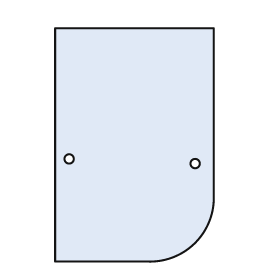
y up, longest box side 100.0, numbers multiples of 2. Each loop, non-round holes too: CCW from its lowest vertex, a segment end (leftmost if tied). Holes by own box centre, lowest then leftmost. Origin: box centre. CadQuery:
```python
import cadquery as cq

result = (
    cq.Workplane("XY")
    .moveTo(-34.0, -50.0)
    .lineTo(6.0, -50.0)
    .threePointArc((26.0, -42.0), (34.0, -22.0))
    .lineTo(34.0, 50.0)
    .lineTo(-34.0, 50.0)
    .close()
    .moveTo(26.0, -8.0)
    .circle(2.0)
    .moveTo(-28.0, -6.0)
    .circle(2.0)
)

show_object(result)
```